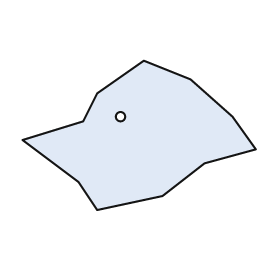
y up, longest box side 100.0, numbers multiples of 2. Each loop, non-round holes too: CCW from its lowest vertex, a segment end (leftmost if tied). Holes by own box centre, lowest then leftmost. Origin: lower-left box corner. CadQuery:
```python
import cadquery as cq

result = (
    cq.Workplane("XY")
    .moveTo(32.0, 0.0)
    .lineTo(60.0, 6.0)
    .lineTo(78.0, 20.0)
    .lineTo(100.0, 26.0)
    .lineTo(90.0, 40.0)
    .lineTo(72.0, 56.0)
    .lineTo(52.0, 64.0)
    .lineTo(32.0, 50.0)
    .lineTo(26.0, 38.0)
    .lineTo(0.0, 30.0)
    .lineTo(24.0, 12.0)
    .close()
    .moveTo(42.0, 40.0)
    .circle(2.0)
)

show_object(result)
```